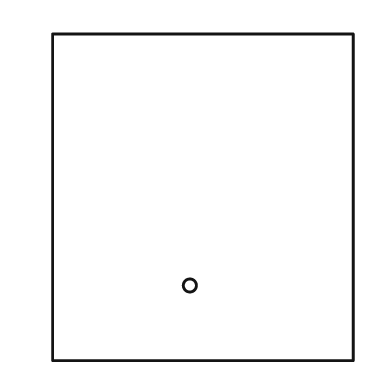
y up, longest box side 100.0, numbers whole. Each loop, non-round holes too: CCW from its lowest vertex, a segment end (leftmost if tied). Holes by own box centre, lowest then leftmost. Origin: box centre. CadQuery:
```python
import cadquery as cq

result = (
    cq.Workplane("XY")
    .moveTo(-46.0, -50.0)
    .lineTo(46.0, -50.0)
    .lineTo(46.0, 50.0)
    .lineTo(-46.0, 50.0)
    .close()
    .moveTo(-4.0, -27.0)
    .circle(2.0)
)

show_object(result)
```